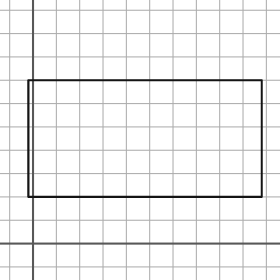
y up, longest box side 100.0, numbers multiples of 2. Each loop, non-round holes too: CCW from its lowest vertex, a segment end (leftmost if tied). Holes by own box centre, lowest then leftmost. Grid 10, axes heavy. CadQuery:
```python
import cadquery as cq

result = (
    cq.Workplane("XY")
    .moveTo(-2.0, 20.0)
    .lineTo(98.0, 20.0)
    .lineTo(98.0, 70.0)
    .lineTo(-2.0, 70.0)
    .close()
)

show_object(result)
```